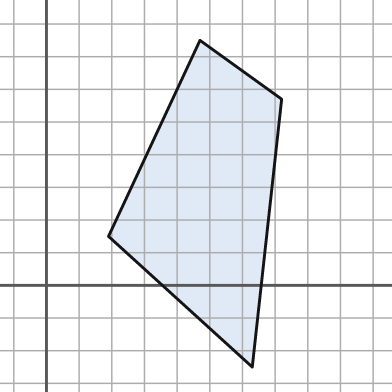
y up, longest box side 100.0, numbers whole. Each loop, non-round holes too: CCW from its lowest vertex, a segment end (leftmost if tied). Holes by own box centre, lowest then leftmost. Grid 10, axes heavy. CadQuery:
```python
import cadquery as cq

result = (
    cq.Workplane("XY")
    .moveTo(63.0, -25.0)
    .lineTo(72.0, 57.0)
    .lineTo(47.0, 75.0)
    .lineTo(19.0, 15.0)
    .close()
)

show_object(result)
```